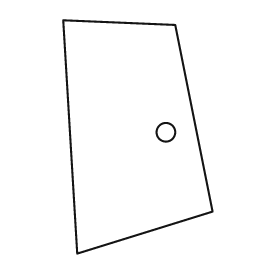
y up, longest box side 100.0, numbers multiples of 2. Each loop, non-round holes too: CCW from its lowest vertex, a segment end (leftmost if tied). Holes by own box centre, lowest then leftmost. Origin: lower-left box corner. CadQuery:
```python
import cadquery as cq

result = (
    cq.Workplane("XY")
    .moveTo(6.0, 0.0)
    .lineTo(64.0, 18.0)
    .lineTo(48.0, 98.0)
    .lineTo(0.0, 100.0)
    .close()
    .moveTo(44.0, 52.0)
    .circle(4.0)
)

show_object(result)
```